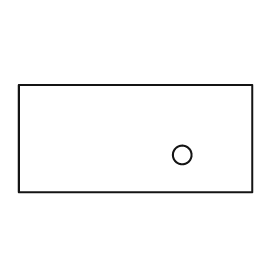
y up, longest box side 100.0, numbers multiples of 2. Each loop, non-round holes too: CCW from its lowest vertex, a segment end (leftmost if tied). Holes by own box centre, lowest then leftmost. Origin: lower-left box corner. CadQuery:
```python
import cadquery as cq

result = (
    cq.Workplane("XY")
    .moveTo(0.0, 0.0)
    .lineTo(100.0, 0.0)
    .lineTo(100.0, 46.0)
    .lineTo(0.0, 46.0)
    .close()
    .moveTo(70.0, 16.0)
    .circle(4.0)
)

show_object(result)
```